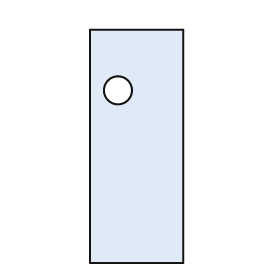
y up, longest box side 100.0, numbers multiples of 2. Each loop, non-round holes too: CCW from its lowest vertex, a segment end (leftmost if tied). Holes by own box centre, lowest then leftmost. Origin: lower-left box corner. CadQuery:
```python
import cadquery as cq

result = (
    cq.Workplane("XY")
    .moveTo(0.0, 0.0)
    .lineTo(40.0, 0.0)
    .lineTo(40.0, 100.0)
    .lineTo(0.0, 100.0)
    .close()
    .moveTo(12.0, 74.0)
    .circle(6.0)
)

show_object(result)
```